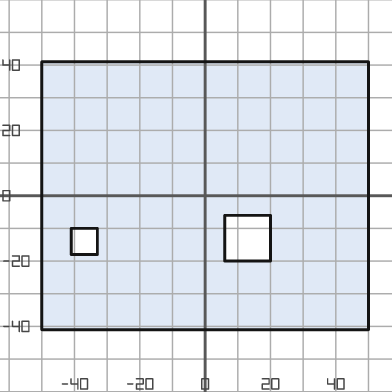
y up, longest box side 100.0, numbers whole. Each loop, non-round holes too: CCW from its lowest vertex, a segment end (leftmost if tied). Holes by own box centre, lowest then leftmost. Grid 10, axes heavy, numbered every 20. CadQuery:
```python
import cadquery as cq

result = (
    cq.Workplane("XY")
    .moveTo(-50.0, -41.0)
    .lineTo(50.0, -41.0)
    .lineTo(50.0, 41.0)
    .lineTo(-50.0, 41.0)
    .close()
    .moveTo(-41.0, -18.0)
    .lineTo(-33.0, -18.0)
    .lineTo(-33.0, -10.0)
    .lineTo(-41.0, -10.0)
    .close()
    .moveTo(6.0, -20.0)
    .lineTo(20.0, -20.0)
    .lineTo(20.0, -6.0)
    .lineTo(6.0, -6.0)
    .close()
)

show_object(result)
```